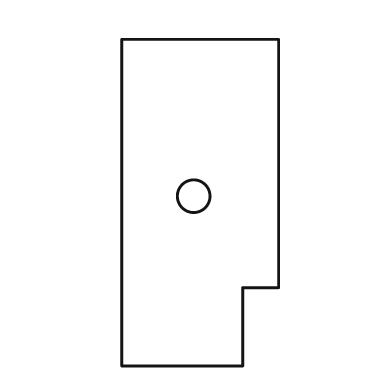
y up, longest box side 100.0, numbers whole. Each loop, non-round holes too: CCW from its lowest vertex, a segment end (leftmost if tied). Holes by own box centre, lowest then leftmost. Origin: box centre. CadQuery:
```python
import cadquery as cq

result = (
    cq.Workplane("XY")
    .moveTo(-24.0, -50.0)
    .lineTo(13.0, -50.0)
    .lineTo(13.0, -26.0)
    .lineTo(24.0, -26.0)
    .lineTo(24.0, 50.0)
    .lineTo(-24.0, 50.0)
    .close()
    .moveTo(-2.0, 2.0)
    .circle(5.0)
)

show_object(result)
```